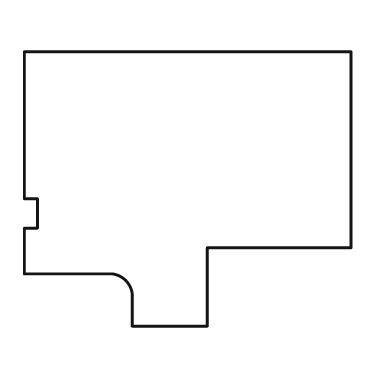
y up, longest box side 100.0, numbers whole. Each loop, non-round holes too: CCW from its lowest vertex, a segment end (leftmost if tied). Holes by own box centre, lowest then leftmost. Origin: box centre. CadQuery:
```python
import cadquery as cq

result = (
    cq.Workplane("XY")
    .moveTo(-17.0, -42.0)
    .lineTo(6.0, -42.0)
    .lineTo(6.0, -18.0)
    .lineTo(50.0, -18.0)
    .lineTo(50.0, 42.0)
    .lineTo(-50.0, 42.0)
    .lineTo(-50.0, -3.0)
    .lineTo(-46.0, -3.0)
    .lineTo(-46.0, -12.0)
    .lineTo(-50.0, -12.0)
    .lineTo(-50.0, -26.0)
    .lineTo(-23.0, -26.0)
    .threePointArc((-19.0, -28.0), (-17.0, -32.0))
    .close()
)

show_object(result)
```